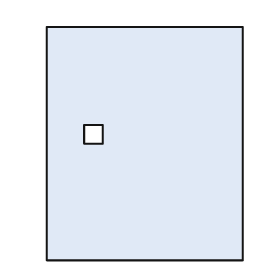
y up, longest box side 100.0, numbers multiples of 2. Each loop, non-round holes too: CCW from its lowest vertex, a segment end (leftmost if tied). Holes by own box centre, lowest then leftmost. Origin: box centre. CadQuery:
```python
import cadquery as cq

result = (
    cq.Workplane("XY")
    .moveTo(-42.0, -50.0)
    .lineTo(42.0, -50.0)
    .lineTo(42.0, 50.0)
    .lineTo(-42.0, 50.0)
    .close()
    .moveTo(-26.0, 0.0)
    .lineTo(-18.0, 0.0)
    .lineTo(-18.0, 8.0)
    .lineTo(-26.0, 8.0)
    .close()
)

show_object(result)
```